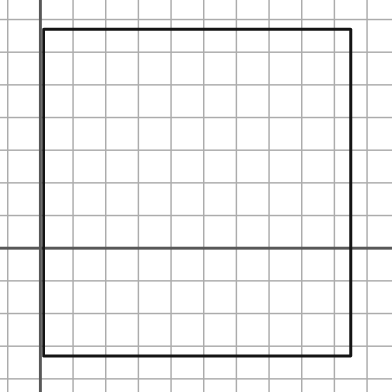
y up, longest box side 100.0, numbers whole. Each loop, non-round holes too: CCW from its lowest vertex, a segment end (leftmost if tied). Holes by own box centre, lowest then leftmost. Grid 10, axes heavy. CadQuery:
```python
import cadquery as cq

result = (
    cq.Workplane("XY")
    .moveTo(1.0, -33.0)
    .lineTo(95.0, -33.0)
    .lineTo(95.0, 67.0)
    .lineTo(1.0, 67.0)
    .close()
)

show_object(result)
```